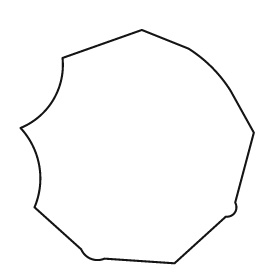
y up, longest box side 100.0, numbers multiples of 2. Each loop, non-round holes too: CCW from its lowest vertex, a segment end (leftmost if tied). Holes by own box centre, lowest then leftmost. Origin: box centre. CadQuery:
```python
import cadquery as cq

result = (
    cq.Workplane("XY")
    .moveTo(16.0, -50.0)
    .lineTo(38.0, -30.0)
    .threePointArc((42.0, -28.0), (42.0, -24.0))
    .lineTo(50.0, 6.0)
    .lineTo(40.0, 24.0)
    .threePointArc((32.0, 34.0), (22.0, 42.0))
    .lineTo(2.0, 50.0)
    .lineTo(-32.0, 38.0)
    .threePointArc((-36.0, 20.0), (-50.0, 8.0))
    .threePointArc((-42.0, -8.0), (-44.0, -26.0))
    .lineTo(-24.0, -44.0)
    .threePointArc((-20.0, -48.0), (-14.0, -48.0))
    .close()
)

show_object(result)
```